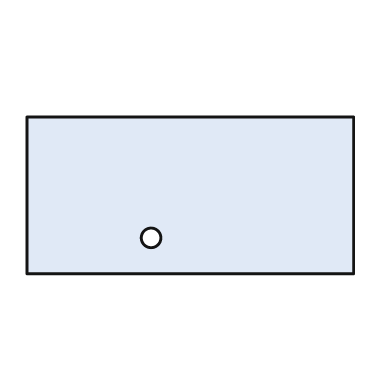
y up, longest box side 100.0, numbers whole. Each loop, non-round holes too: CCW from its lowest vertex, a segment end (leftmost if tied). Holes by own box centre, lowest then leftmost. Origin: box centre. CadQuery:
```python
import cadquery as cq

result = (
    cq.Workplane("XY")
    .moveTo(-50.0, -24.0)
    .lineTo(50.0, -24.0)
    .lineTo(50.0, 24.0)
    .lineTo(-50.0, 24.0)
    .close()
    .moveTo(-12.0, -13.0)
    .circle(3.0)
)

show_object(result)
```